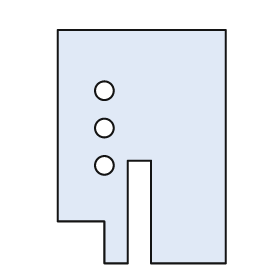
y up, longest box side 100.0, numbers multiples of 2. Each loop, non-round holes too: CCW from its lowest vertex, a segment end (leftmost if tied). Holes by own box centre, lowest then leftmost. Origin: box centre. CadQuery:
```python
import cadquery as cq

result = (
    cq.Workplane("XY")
    .moveTo(-16.0, -50.0)
    .lineTo(-6.0, -50.0)
    .lineTo(-6.0, -6.0)
    .lineTo(4.0, -6.0)
    .lineTo(4.0, -50.0)
    .lineTo(36.0, -50.0)
    .lineTo(36.0, 50.0)
    .lineTo(-36.0, 50.0)
    .lineTo(-36.0, -32.0)
    .lineTo(-16.0, -32.0)
    .close()
    .moveTo(-16.0, -8.0)
    .circle(4.0)
    .moveTo(-16.0, 8.0)
    .circle(4.0)
    .moveTo(-16.0, 24.0)
    .circle(4.0)
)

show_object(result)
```